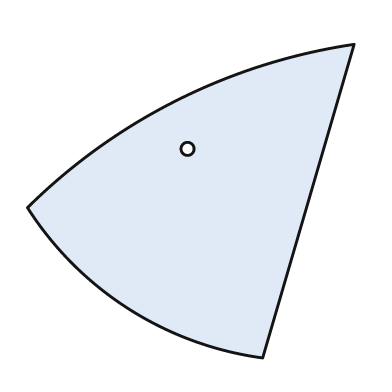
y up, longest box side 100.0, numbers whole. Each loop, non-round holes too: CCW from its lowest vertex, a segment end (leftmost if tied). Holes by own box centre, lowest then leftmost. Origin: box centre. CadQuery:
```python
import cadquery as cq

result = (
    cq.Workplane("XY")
    .moveTo(22.0, -48.0)
    .lineTo(50.0, 48.0)
    .threePointArc((-4.0, 31.0), (-50.0, -2.0))
    .threePointArc((-19.0, -33.0), (22.0, -48.0))
    .close()
    .moveTo(-1.0, 16.0)
    .circle(2.0)
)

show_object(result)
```